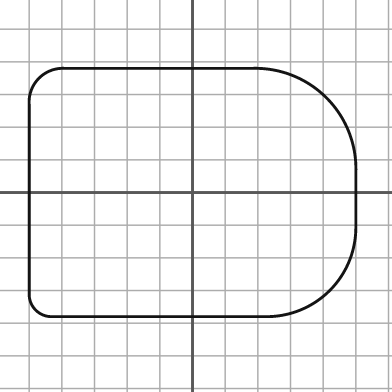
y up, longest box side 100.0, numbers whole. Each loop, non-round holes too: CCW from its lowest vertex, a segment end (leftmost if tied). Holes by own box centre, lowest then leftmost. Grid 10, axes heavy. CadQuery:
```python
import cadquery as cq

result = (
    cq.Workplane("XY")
    .moveTo(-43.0, -38.0)
    .lineTo(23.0, -38.0)
    .threePointArc((42.0, -30.0), (50.0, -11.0))
    .lineTo(50.0, 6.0)
    .threePointArc((41.0, 29.0), (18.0, 38.0))
    .lineTo(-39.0, 38.0)
    .threePointArc((-47.0, 35.0), (-50.0, 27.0))
    .lineTo(-50.0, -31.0)
    .threePointArc((-48.0, -36.0), (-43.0, -38.0))
    .close()
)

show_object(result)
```